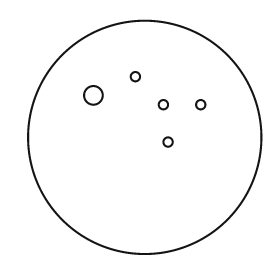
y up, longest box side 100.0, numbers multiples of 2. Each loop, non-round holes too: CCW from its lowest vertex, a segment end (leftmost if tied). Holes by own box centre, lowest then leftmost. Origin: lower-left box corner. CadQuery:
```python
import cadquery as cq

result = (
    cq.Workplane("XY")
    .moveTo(50.0, 50.0)
    .circle(50.0)
    .moveTo(60.0, 48.0)
    .circle(2.0)
    .moveTo(58.0, 64.0)
    .circle(2.0)
    .moveTo(74.0, 64.0)
    .circle(2.0)
    .moveTo(28.0, 68.0)
    .circle(4.0)
    .moveTo(46.0, 76.0)
    .circle(2.0)
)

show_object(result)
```